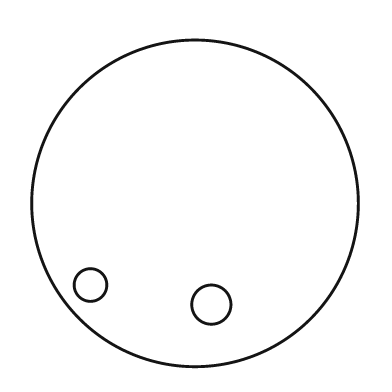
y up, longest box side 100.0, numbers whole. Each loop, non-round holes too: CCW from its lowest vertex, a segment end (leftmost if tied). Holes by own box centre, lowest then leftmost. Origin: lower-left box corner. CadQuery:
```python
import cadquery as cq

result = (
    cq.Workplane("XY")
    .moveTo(50.0, 50.0)
    .circle(50.0)
    .moveTo(55.0, 19.0)
    .circle(6.0)
    .moveTo(18.0, 25.0)
    .circle(5.0)
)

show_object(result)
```